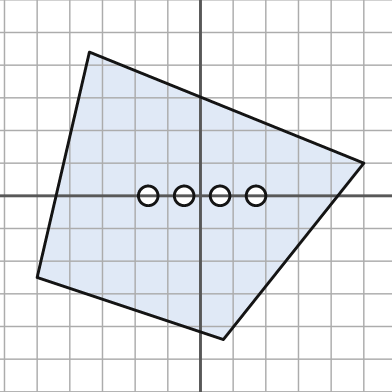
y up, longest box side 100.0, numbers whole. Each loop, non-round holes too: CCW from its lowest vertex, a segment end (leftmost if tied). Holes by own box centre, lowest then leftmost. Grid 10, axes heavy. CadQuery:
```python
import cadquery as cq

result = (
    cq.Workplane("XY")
    .moveTo(7.0, -44.0)
    .lineTo(50.0, 10.0)
    .lineTo(-34.0, 44.0)
    .lineTo(-50.0, -25.0)
    .close()
    .moveTo(-16.0, 0.0)
    .circle(3.0)
    .moveTo(-5.0, 0.0)
    .circle(3.0)
    .moveTo(6.0, 0.0)
    .circle(3.0)
    .moveTo(17.0, 0.0)
    .circle(3.0)
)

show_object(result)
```